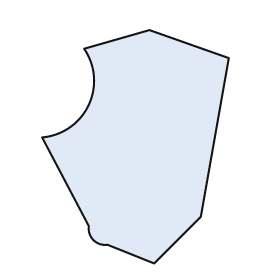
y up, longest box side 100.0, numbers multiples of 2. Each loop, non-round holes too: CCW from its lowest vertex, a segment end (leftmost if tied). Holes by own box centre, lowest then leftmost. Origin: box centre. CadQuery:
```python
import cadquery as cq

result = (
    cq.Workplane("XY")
    .moveTo(8.0, -50.0)
    .lineTo(28.0, -30.0)
    .lineTo(40.0, 38.0)
    .lineTo(6.0, 50.0)
    .lineTo(-22.0, 42.0)
    .threePointArc((-20.0, 18.0), (-40.0, 4.0))
    .lineTo(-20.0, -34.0)
    .threePointArc((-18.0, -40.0), (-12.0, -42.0))
    .close()
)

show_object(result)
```